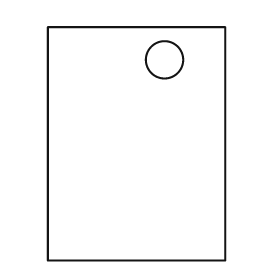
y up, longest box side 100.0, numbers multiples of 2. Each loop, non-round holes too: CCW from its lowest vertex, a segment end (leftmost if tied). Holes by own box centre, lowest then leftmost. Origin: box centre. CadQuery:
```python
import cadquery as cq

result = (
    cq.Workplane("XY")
    .moveTo(-38.0, -50.0)
    .lineTo(38.0, -50.0)
    .lineTo(38.0, 50.0)
    .lineTo(-38.0, 50.0)
    .close()
    .moveTo(12.0, 36.0)
    .circle(8.0)
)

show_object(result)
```